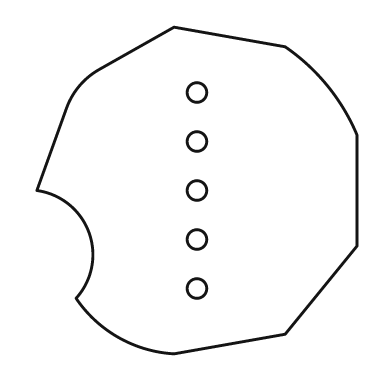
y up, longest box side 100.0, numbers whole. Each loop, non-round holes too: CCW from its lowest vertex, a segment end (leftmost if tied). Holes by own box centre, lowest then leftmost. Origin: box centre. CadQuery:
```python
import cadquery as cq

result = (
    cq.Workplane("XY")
    .moveTo(-7.0, -50.0)
    .lineTo(27.0, -44.0)
    .lineTo(49.0, -17.0)
    .lineTo(49.0, 17.0)
    .threePointArc((40.0, 32.0), (27.0, 44.0))
    .lineTo(-7.0, 50.0)
    .lineTo(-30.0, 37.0)
    .threePointArc((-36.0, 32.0), (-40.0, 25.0))
    .lineTo(-49.0, 0.0)
    .threePointArc((-33.0, -13.0), (-37.0, -33.0))
    .threePointArc((-24.0, -45.0), (-7.0, -50.0))
    .close()
    .moveTo(0.0, -30.0)
    .circle(3.0)
    .moveTo(0.0, -15.0)
    .circle(3.0)
    .moveTo(0.0, 0.0)
    .circle(3.0)
    .moveTo(0.0, 15.0)
    .circle(3.0)
    .moveTo(0.0, 30.0)
    .circle(3.0)
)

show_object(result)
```